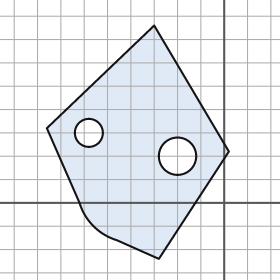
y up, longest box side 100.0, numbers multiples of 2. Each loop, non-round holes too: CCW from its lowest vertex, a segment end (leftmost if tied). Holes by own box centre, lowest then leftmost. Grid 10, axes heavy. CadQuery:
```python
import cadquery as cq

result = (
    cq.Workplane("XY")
    .moveTo(-28.0, -24.0)
    .lineTo(2.0, 22.0)
    .lineTo(-30.0, 76.0)
    .lineTo(-76.0, 32.0)
    .lineTo(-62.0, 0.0)
    .threePointArc((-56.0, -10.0), (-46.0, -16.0))
    .close()
    .moveTo(-20.0, 20.0)
    .circle(8.0)
    .moveTo(-58.0, 30.0)
    .circle(6.0)
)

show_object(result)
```